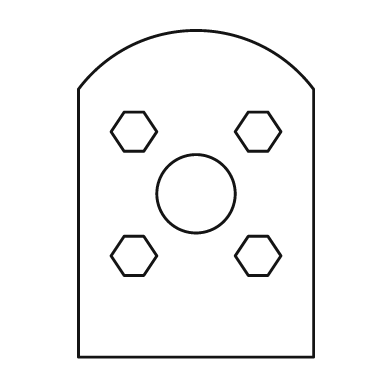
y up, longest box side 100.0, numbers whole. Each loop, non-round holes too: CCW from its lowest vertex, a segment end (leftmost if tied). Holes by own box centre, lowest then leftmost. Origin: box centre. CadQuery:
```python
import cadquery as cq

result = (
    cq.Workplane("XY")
    .moveTo(-36.0, -50.0)
    .lineTo(36.0, -50.0)
    .lineTo(36.0, 32.0)
    .threePointArc((0.0, 50.0), (-36.0, 32.0))
    .close()
    .moveTo(-22.0, -25.0)
    .lineTo(-16.0, -25.0)
    .lineTo(-12.0, -19.0)
    .lineTo(-16.0, -13.0)
    .lineTo(-22.0, -13.0)
    .lineTo(-26.0, -19.0)
    .close()
    .moveTo(16.0, -25.0)
    .lineTo(22.0, -25.0)
    .lineTo(26.0, -19.0)
    .lineTo(22.0, -13.0)
    .lineTo(16.0, -13.0)
    .lineTo(12.0, -19.0)
    .close()
    .moveTo(0.0, 0.0)
    .circle(12.0)
    .moveTo(-22.0, 13.0)
    .lineTo(-16.0, 13.0)
    .lineTo(-12.0, 19.0)
    .lineTo(-16.0, 25.0)
    .lineTo(-22.0, 25.0)
    .lineTo(-26.0, 19.0)
    .close()
    .moveTo(16.0, 13.0)
    .lineTo(22.0, 13.0)
    .lineTo(26.0, 19.0)
    .lineTo(22.0, 25.0)
    .lineTo(16.0, 25.0)
    .lineTo(12.0, 19.0)
    .close()
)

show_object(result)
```